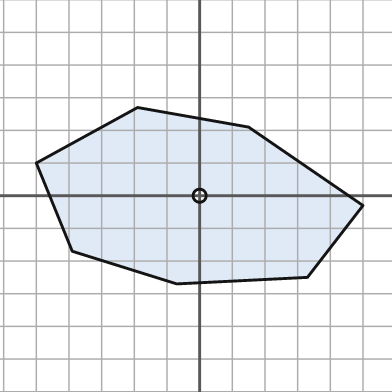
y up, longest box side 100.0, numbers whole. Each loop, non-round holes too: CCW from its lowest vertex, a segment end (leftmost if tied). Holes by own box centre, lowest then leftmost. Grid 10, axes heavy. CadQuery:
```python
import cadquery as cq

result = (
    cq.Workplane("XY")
    .moveTo(-7.0, -27.0)
    .lineTo(33.0, -25.0)
    .lineTo(50.0, -3.0)
    .lineTo(15.0, 21.0)
    .lineTo(-19.0, 27.0)
    .lineTo(-50.0, 10.0)
    .lineTo(-39.0, -17.0)
    .close()
    .moveTo(0.0, 0.0)
    .circle(2.0)
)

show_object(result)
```